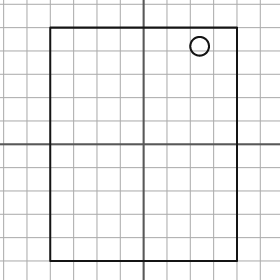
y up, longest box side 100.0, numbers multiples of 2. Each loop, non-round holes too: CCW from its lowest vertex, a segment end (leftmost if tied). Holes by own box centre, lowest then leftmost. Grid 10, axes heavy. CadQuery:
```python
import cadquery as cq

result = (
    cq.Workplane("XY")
    .moveTo(-40.0, -50.0)
    .lineTo(40.0, -50.0)
    .lineTo(40.0, 50.0)
    .lineTo(-40.0, 50.0)
    .close()
    .moveTo(24.0, 42.0)
    .circle(4.0)
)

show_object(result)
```